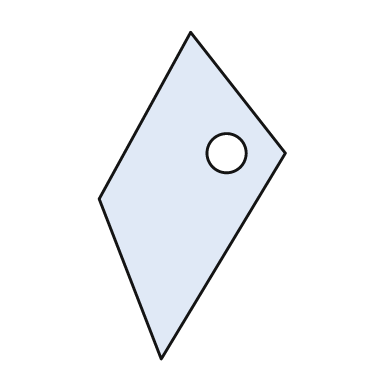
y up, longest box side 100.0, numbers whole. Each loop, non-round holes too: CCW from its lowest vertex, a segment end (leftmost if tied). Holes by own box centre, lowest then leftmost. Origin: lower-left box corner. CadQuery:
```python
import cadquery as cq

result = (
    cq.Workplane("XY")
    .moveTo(19.0, 0.0)
    .lineTo(57.0, 63.0)
    .lineTo(28.0, 100.0)
    .lineTo(0.0, 49.0)
    .close()
    .moveTo(39.0, 63.0)
    .circle(6.0)
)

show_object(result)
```